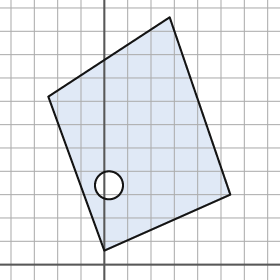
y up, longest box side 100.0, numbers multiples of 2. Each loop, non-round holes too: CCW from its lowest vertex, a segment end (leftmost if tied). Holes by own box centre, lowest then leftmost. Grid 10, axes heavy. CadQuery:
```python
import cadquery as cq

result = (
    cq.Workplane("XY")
    .moveTo(0.0, 6.0)
    .lineTo(54.0, 30.0)
    .lineTo(28.0, 106.0)
    .lineTo(-24.0, 72.0)
    .close()
    .moveTo(2.0, 34.0)
    .circle(6.0)
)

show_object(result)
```